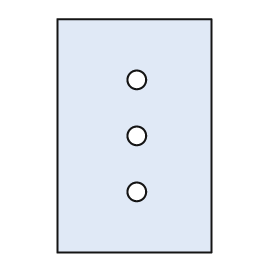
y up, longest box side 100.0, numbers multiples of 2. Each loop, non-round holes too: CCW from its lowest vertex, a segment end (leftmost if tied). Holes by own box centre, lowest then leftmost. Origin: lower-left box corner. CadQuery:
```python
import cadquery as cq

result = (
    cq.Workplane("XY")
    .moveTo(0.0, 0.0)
    .lineTo(66.0, 0.0)
    .lineTo(66.0, 100.0)
    .lineTo(0.0, 100.0)
    .close()
    .moveTo(34.0, 26.0)
    .circle(4.0)
    .moveTo(34.0, 50.0)
    .circle(4.0)
    .moveTo(34.0, 74.0)
    .circle(4.0)
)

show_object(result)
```